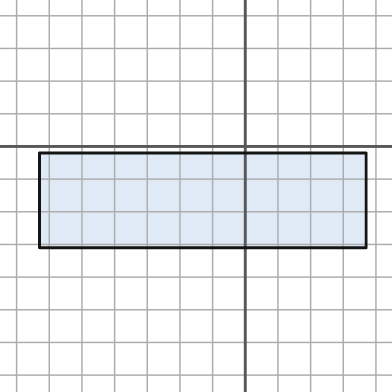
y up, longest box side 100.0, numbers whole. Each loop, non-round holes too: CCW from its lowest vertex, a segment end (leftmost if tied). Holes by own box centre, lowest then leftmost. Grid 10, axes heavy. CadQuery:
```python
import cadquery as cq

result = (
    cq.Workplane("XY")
    .moveTo(-63.0, -31.0)
    .lineTo(37.0, -31.0)
    .lineTo(37.0, -2.0)
    .lineTo(-63.0, -2.0)
    .close()
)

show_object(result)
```